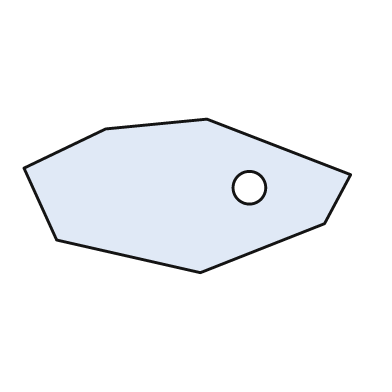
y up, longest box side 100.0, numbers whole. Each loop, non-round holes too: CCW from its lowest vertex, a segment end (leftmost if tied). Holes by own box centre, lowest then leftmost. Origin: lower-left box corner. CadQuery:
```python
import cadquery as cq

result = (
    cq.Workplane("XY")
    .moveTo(54.0, 0.0)
    .lineTo(92.0, 15.0)
    .lineTo(100.0, 30.0)
    .lineTo(56.0, 47.0)
    .lineTo(25.0, 44.0)
    .lineTo(0.0, 32.0)
    .lineTo(10.0, 10.0)
    .close()
    .moveTo(69.0, 26.0)
    .circle(5.0)
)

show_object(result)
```